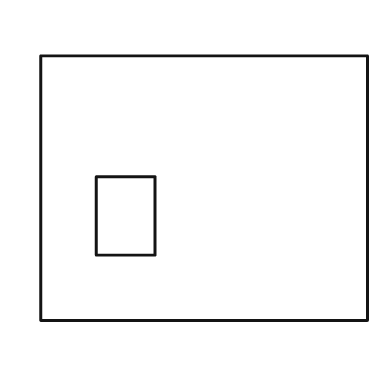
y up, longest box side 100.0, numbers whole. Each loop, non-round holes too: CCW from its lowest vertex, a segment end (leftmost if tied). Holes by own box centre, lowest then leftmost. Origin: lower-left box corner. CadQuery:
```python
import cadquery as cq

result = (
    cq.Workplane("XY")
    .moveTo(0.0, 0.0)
    .lineTo(100.0, 0.0)
    .lineTo(100.0, 81.0)
    .lineTo(0.0, 81.0)
    .close()
    .moveTo(17.0, 20.0)
    .lineTo(35.0, 20.0)
    .lineTo(35.0, 44.0)
    .lineTo(17.0, 44.0)
    .close()
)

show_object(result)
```